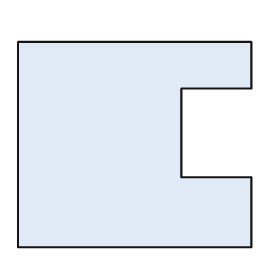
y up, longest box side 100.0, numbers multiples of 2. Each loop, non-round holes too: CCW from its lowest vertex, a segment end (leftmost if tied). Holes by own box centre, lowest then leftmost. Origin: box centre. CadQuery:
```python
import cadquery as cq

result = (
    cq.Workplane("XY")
    .moveTo(-50.0, -44.0)
    .lineTo(50.0, -44.0)
    .lineTo(50.0, -14.0)
    .lineTo(20.0, -14.0)
    .lineTo(20.0, 24.0)
    .lineTo(50.0, 24.0)
    .lineTo(50.0, 44.0)
    .lineTo(-50.0, 44.0)
    .close()
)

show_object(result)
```